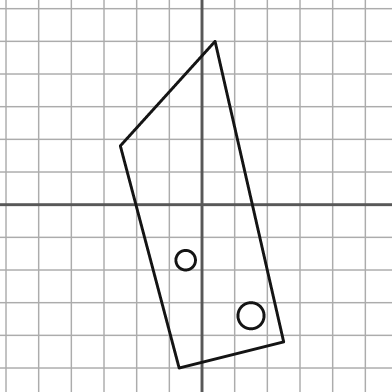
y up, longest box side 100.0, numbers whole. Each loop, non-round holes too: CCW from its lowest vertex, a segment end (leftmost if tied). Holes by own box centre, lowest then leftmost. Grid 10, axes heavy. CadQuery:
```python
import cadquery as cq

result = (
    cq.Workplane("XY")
    .moveTo(-7.0, -50.0)
    .lineTo(25.0, -42.0)
    .lineTo(4.0, 50.0)
    .lineTo(-25.0, 18.0)
    .close()
    .moveTo(15.0, -34.0)
    .circle(4.0)
    .moveTo(-5.0, -17.0)
    .circle(3.0)
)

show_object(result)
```